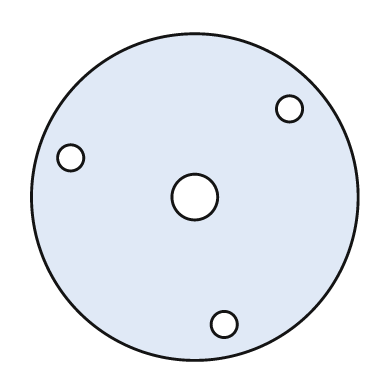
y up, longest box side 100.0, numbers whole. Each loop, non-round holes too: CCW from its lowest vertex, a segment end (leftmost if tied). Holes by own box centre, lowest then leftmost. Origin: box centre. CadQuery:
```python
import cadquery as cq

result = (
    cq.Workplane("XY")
    .moveTo(0.0, 0.0)
    .circle(50.0)
    .moveTo(9.0, -39.0)
    .circle(4.0)
    .moveTo(0.0, 0.0)
    .circle(7.0)
    .moveTo(-38.0, 12.0)
    .circle(4.0)
    .moveTo(29.0, 27.0)
    .circle(4.0)
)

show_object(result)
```